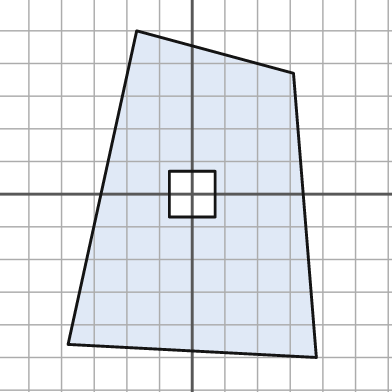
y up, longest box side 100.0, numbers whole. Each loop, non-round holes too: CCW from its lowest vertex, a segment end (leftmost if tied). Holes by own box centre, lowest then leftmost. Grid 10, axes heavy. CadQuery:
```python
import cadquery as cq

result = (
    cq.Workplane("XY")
    .moveTo(38.0, -50.0)
    .lineTo(31.0, 37.0)
    .lineTo(-17.0, 50.0)
    .lineTo(-38.0, -46.0)
    .close()
    .moveTo(-7.0, -7.0)
    .lineTo(7.0, -7.0)
    .lineTo(7.0, 7.0)
    .lineTo(-7.0, 7.0)
    .close()
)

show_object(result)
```